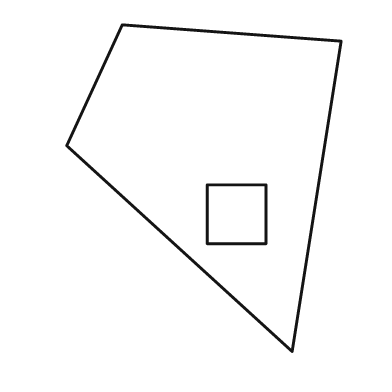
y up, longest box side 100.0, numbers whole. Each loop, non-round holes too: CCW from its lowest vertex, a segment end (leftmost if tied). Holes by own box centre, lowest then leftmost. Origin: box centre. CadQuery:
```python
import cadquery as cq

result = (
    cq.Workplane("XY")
    .moveTo(27.0, -50.0)
    .lineTo(42.0, 45.0)
    .lineTo(-25.0, 50.0)
    .lineTo(-42.0, 13.0)
    .close()
    .moveTo(1.0, -17.0)
    .lineTo(19.0, -17.0)
    .lineTo(19.0, 1.0)
    .lineTo(1.0, 1.0)
    .close()
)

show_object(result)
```